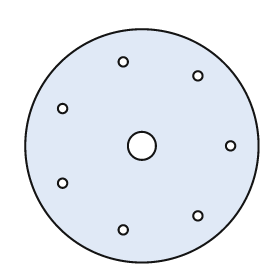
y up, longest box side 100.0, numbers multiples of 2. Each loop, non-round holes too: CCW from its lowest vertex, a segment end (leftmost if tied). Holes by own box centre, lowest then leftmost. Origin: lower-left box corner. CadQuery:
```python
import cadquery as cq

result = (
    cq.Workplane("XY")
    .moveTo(50.0, 50.0)
    .circle(50.0)
    .moveTo(42.0, 14.0)
    .circle(2.0)
    .moveTo(74.0, 20.0)
    .circle(2.0)
    .moveTo(16.0, 34.0)
    .circle(2.0)
    .moveTo(50.0, 50.0)
    .circle(6.0)
    .moveTo(88.0, 50.0)
    .circle(2.0)
    .moveTo(16.0, 66.0)
    .circle(2.0)
    .moveTo(74.0, 80.0)
    .circle(2.0)
    .moveTo(42.0, 86.0)
    .circle(2.0)
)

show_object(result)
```